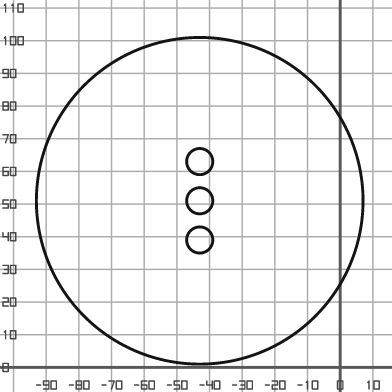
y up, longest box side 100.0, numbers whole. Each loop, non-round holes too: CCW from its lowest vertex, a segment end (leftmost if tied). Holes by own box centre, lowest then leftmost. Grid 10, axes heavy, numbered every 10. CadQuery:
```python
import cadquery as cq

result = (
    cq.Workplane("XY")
    .moveTo(-43.0, 51.0)
    .circle(50.0)
    .moveTo(-43.0, 39.0)
    .circle(4.0)
    .moveTo(-43.0, 51.0)
    .circle(4.0)
    .moveTo(-43.0, 63.0)
    .circle(4.0)
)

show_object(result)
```